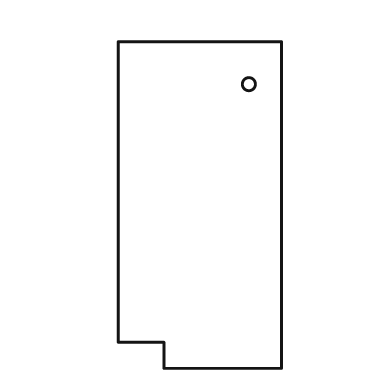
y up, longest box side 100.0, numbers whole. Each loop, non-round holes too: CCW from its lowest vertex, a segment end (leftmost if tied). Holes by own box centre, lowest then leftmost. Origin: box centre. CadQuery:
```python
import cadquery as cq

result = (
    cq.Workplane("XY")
    .moveTo(-11.0, -50.0)
    .lineTo(25.0, -50.0)
    .lineTo(25.0, 50.0)
    .lineTo(-25.0, 50.0)
    .lineTo(-25.0, -42.0)
    .lineTo(-11.0, -42.0)
    .close()
    .moveTo(15.0, 37.0)
    .circle(2.0)
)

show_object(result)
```